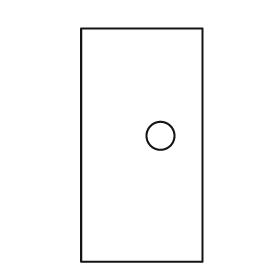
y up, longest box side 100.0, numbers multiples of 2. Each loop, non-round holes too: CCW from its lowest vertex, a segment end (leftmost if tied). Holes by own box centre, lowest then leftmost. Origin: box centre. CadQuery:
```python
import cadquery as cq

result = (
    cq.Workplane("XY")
    .moveTo(-26.0, -50.0)
    .lineTo(26.0, -50.0)
    .lineTo(26.0, 50.0)
    .lineTo(-26.0, 50.0)
    .close()
    .moveTo(8.0, 4.0)
    .circle(6.0)
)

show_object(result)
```